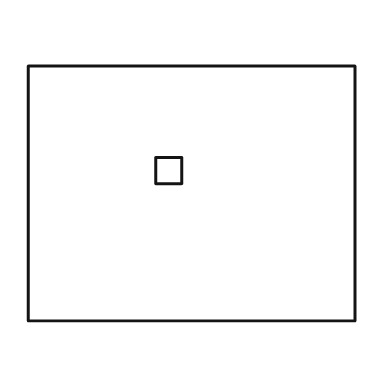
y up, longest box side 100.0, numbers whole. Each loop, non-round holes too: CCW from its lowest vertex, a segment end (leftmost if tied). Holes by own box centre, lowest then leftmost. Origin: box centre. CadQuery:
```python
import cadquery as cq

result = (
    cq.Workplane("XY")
    .moveTo(-50.0, -39.0)
    .lineTo(50.0, -39.0)
    .lineTo(50.0, 39.0)
    .lineTo(-50.0, 39.0)
    .close()
    .moveTo(-11.0, 3.0)
    .lineTo(-3.0, 3.0)
    .lineTo(-3.0, 11.0)
    .lineTo(-11.0, 11.0)
    .close()
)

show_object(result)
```